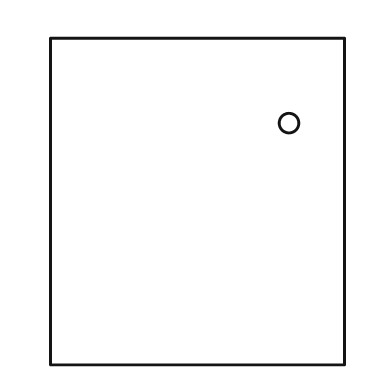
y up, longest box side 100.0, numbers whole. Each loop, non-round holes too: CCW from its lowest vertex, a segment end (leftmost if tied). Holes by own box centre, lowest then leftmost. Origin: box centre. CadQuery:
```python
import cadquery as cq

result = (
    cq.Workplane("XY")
    .moveTo(-45.0, -50.0)
    .lineTo(45.0, -50.0)
    .lineTo(45.0, 50.0)
    .lineTo(-45.0, 50.0)
    .close()
    .moveTo(28.0, 24.0)
    .circle(3.0)
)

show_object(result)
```